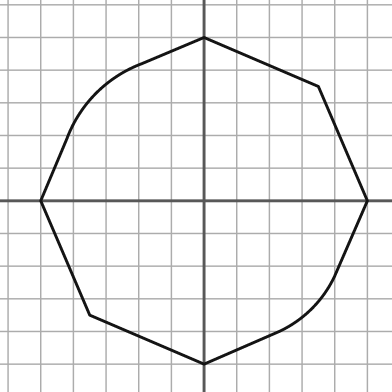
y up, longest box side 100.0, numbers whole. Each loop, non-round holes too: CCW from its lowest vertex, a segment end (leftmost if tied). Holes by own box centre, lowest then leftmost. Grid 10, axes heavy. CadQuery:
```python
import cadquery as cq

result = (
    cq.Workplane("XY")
    .moveTo(0.0, -50.0)
    .lineTo(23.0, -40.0)
    .threePointArc((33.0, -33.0), (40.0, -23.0))
    .lineTo(50.0, 0.0)
    .lineTo(35.0, 35.0)
    .lineTo(0.0, 50.0)
    .lineTo(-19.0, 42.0)
    .threePointArc((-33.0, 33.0), (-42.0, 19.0))
    .lineTo(-50.0, 0.0)
    .lineTo(-35.0, -35.0)
    .close()
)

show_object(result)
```